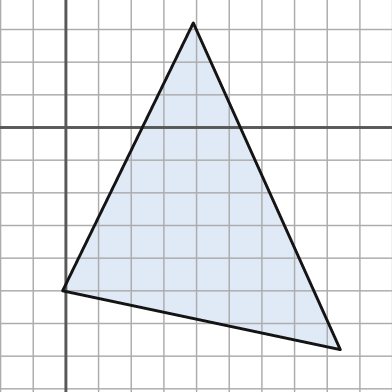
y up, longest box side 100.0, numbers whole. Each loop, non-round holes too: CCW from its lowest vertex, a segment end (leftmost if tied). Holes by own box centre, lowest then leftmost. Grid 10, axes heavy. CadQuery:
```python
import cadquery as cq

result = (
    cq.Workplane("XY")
    .moveTo(84.0, -68.0)
    .lineTo(39.0, 32.0)
    .lineTo(-1.0, -50.0)
    .close()
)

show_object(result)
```